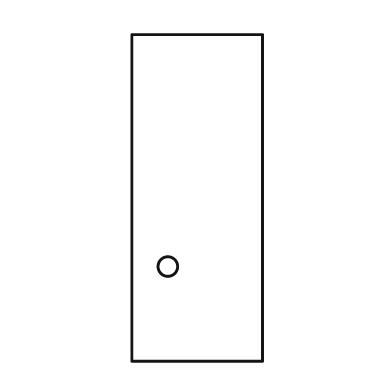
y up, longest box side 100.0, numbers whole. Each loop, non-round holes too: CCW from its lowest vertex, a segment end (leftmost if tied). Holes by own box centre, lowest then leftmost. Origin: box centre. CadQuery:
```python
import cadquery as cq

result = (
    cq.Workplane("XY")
    .moveTo(-20.0, -50.0)
    .lineTo(20.0, -50.0)
    .lineTo(20.0, 50.0)
    .lineTo(-20.0, 50.0)
    .close()
    .moveTo(-9.0, -21.0)
    .circle(3.0)
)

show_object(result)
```